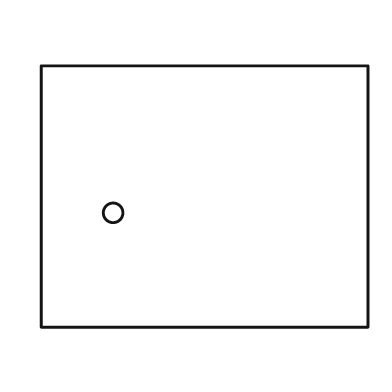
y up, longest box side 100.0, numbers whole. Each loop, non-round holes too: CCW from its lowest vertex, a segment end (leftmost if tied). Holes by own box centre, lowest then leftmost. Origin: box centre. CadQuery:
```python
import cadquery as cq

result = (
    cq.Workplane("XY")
    .moveTo(-50.0, -40.0)
    .lineTo(50.0, -40.0)
    .lineTo(50.0, 40.0)
    .lineTo(-50.0, 40.0)
    .close()
    .moveTo(-28.0, -5.0)
    .circle(3.0)
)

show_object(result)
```